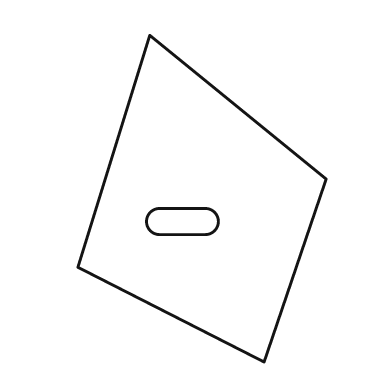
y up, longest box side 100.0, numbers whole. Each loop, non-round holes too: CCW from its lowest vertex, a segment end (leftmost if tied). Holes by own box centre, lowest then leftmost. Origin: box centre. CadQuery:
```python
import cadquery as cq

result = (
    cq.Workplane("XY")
    .moveTo(19.0, -50.0)
    .lineTo(38.0, 6.0)
    .lineTo(-16.0, 50.0)
    .lineTo(-38.0, -21.0)
    .close()
    .moveTo(-13.0, -11.0)
    .lineTo(1.0, -11.0)
    .threePointArc((5.0, -7.0), (1.0, -3.0))
    .lineTo(-13.0, -3.0)
    .threePointArc((-17.0, -7.0), (-13.0, -11.0))
    .close()
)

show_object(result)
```